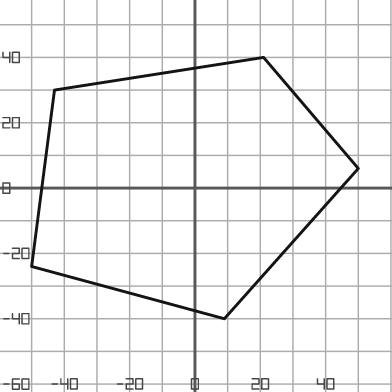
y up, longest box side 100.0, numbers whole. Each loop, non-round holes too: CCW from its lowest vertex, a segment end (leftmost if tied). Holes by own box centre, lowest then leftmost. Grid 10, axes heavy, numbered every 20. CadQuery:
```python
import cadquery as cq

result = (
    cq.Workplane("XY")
    .moveTo(9.0, -40.0)
    .lineTo(50.0, 6.0)
    .lineTo(21.0, 40.0)
    .lineTo(-43.0, 30.0)
    .lineTo(-50.0, -24.0)
    .close()
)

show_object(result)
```